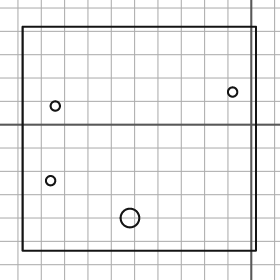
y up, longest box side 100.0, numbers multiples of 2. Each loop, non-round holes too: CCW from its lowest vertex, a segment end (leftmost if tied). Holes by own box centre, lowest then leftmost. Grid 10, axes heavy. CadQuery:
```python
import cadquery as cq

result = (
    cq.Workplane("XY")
    .moveTo(-98.0, -54.0)
    .lineTo(2.0, -54.0)
    .lineTo(2.0, 42.0)
    .lineTo(-98.0, 42.0)
    .close()
    .moveTo(-52.0, -40.0)
    .circle(4.0)
    .moveTo(-86.0, -24.0)
    .circle(2.0)
    .moveTo(-84.0, 8.0)
    .circle(2.0)
    .moveTo(-8.0, 14.0)
    .circle(2.0)
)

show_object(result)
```